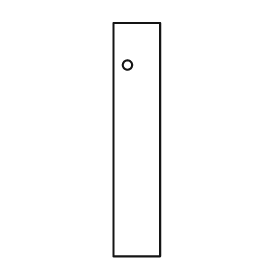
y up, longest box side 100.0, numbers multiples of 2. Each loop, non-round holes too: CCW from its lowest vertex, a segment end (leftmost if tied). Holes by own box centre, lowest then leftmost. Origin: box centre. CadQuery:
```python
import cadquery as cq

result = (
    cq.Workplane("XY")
    .moveTo(-10.0, -50.0)
    .lineTo(10.0, -50.0)
    .lineTo(10.0, 50.0)
    .lineTo(-10.0, 50.0)
    .close()
    .moveTo(-4.0, 32.0)
    .circle(2.0)
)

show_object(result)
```